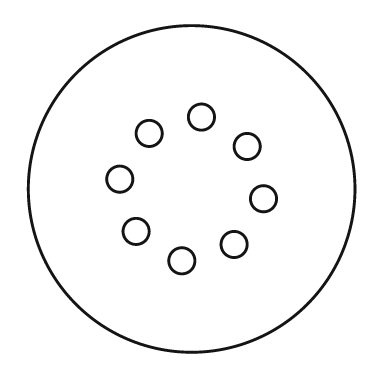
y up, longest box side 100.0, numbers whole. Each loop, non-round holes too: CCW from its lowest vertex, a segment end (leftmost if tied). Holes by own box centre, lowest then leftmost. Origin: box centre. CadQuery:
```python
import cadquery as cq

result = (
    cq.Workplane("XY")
    .moveTo(0.0, 0.0)
    .circle(50.0)
    .moveTo(-3.0, -22.0)
    .circle(4.0)
    .moveTo(13.0, -17.0)
    .circle(4.0)
    .moveTo(-17.0, -13.0)
    .circle(4.0)
    .moveTo(22.0, -3.0)
    .circle(4.0)
    .moveTo(-22.0, 3.0)
    .circle(4.0)
    .moveTo(17.0, 13.0)
    .circle(4.0)
    .moveTo(-13.0, 17.0)
    .circle(4.0)
    .moveTo(3.0, 22.0)
    .circle(4.0)
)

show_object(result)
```